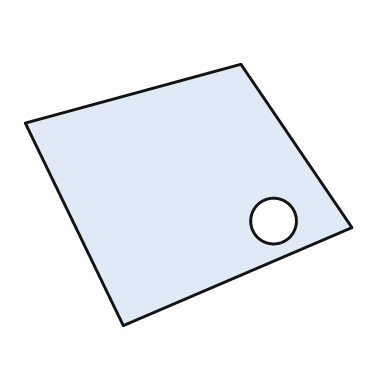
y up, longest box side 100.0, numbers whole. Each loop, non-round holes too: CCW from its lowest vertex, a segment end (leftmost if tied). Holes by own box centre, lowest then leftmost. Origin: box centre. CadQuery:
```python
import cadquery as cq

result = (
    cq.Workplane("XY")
    .moveTo(-20.0, -40.0)
    .lineTo(50.0, -10.0)
    .lineTo(16.0, 40.0)
    .lineTo(-50.0, 22.0)
    .close()
    .moveTo(26.0, -8.0)
    .circle(7.0)
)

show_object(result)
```